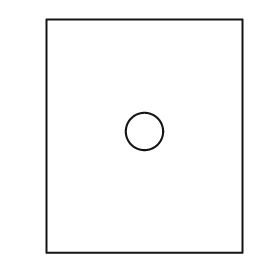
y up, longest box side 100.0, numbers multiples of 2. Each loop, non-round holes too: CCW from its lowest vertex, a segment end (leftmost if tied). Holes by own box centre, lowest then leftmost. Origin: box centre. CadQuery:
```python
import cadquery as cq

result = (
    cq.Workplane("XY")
    .moveTo(-42.0, -50.0)
    .lineTo(42.0, -50.0)
    .lineTo(42.0, 50.0)
    .lineTo(-42.0, 50.0)
    .close()
    .moveTo(0.0, 2.0)
    .circle(8.0)
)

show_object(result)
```